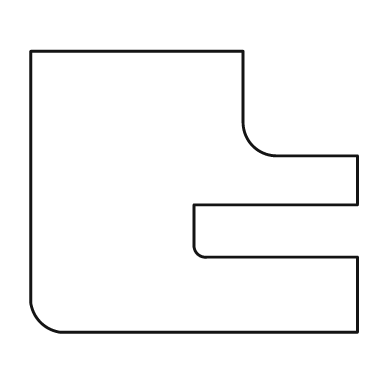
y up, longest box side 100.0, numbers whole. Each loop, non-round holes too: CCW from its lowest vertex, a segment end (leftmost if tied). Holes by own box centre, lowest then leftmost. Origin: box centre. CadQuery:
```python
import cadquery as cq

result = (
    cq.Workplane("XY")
    .moveTo(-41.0, -43.0)
    .lineTo(50.0, -43.0)
    .lineTo(50.0, -20.0)
    .lineTo(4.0, -20.0)
    .threePointArc((1.0, -19.0), (0.0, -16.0))
    .lineTo(0.0, -4.0)
    .lineTo(50.0, -4.0)
    .lineTo(50.0, 11.0)
    .lineTo(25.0, 11.0)
    .threePointArc((18.0, 14.0), (15.0, 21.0))
    .lineTo(15.0, 43.0)
    .lineTo(-50.0, 43.0)
    .lineTo(-50.0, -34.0)
    .threePointArc((-47.0, -40.0), (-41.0, -43.0))
    .close()
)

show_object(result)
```